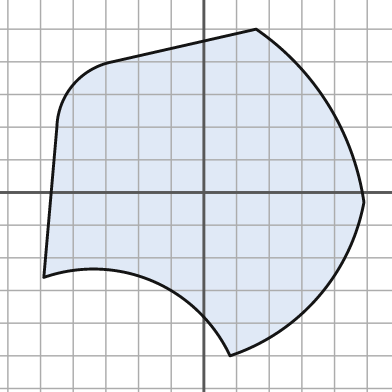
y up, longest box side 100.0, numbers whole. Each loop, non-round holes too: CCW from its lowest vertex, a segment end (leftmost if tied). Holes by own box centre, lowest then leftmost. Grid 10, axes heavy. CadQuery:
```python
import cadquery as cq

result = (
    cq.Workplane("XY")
    .moveTo(8.0, -50.0)
    .threePointArc((35.0, -32.0), (49.0, -3.0))
    .threePointArc((38.0, 27.0), (16.0, 50.0))
    .lineTo(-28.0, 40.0)
    .threePointArc((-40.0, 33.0), (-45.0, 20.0))
    .lineTo(-49.0, -26.0)
    .threePointArc((-16.0, -27.0), (8.0, -50.0))
    .close()
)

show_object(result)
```